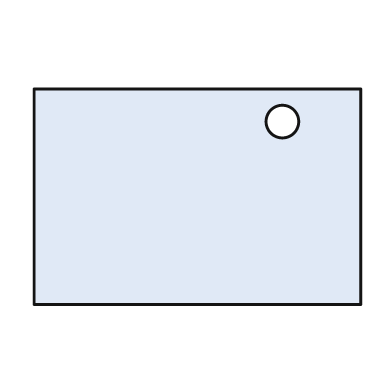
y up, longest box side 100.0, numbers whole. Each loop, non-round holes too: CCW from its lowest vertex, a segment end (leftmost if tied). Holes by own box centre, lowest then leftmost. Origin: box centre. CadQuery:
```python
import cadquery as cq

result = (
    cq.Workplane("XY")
    .moveTo(-50.0, -33.0)
    .lineTo(50.0, -33.0)
    .lineTo(50.0, 33.0)
    .lineTo(-50.0, 33.0)
    .close()
    .moveTo(26.0, 23.0)
    .circle(5.0)
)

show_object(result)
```